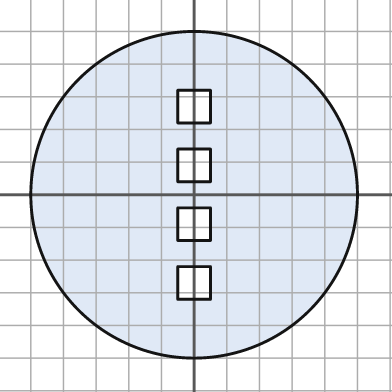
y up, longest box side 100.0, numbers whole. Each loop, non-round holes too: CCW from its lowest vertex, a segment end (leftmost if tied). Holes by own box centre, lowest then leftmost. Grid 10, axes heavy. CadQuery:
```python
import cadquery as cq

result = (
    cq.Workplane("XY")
    .moveTo(0.0, 0.0)
    .circle(50.0)
    .moveTo(-5.0, -32.0)
    .lineTo(5.0, -32.0)
    .lineTo(5.0, -22.0)
    .lineTo(-5.0, -22.0)
    .close()
    .moveTo(-5.0, -14.0)
    .lineTo(5.0, -14.0)
    .lineTo(5.0, -4.0)
    .lineTo(-5.0, -4.0)
    .close()
    .moveTo(-5.0, 4.0)
    .lineTo(5.0, 4.0)
    .lineTo(5.0, 14.0)
    .lineTo(-5.0, 14.0)
    .close()
    .moveTo(-5.0, 22.0)
    .lineTo(5.0, 22.0)
    .lineTo(5.0, 32.0)
    .lineTo(-5.0, 32.0)
    .close()
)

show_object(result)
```